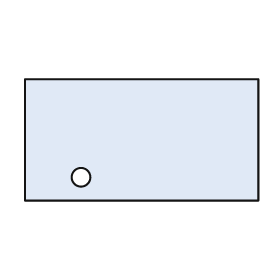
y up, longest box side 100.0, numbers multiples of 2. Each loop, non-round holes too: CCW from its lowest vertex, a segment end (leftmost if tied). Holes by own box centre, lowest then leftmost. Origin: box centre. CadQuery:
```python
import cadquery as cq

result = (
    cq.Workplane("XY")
    .moveTo(-50.0, -26.0)
    .lineTo(50.0, -26.0)
    .lineTo(50.0, 26.0)
    .lineTo(-50.0, 26.0)
    .close()
    .moveTo(-26.0, -16.0)
    .circle(4.0)
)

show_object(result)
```